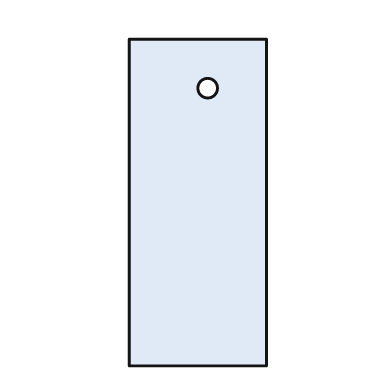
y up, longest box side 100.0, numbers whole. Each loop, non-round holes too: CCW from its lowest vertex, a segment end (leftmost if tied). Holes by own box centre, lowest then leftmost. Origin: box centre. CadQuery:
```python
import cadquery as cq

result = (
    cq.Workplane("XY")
    .moveTo(-21.0, -50.0)
    .lineTo(21.0, -50.0)
    .lineTo(21.0, 50.0)
    .lineTo(-21.0, 50.0)
    .close()
    .moveTo(3.0, 35.0)
    .circle(3.0)
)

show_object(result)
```